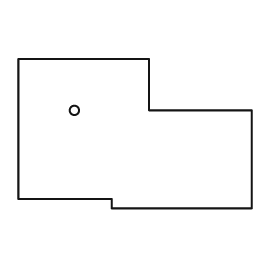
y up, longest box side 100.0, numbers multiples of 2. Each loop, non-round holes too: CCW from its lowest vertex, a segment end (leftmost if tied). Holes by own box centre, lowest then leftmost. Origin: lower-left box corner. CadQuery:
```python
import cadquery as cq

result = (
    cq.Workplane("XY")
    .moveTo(40.0, 0.0)
    .lineTo(100.0, 0.0)
    .lineTo(100.0, 42.0)
    .lineTo(56.0, 42.0)
    .lineTo(56.0, 64.0)
    .lineTo(0.0, 64.0)
    .lineTo(0.0, 4.0)
    .lineTo(40.0, 4.0)
    .close()
    .moveTo(24.0, 42.0)
    .circle(2.0)
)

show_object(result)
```